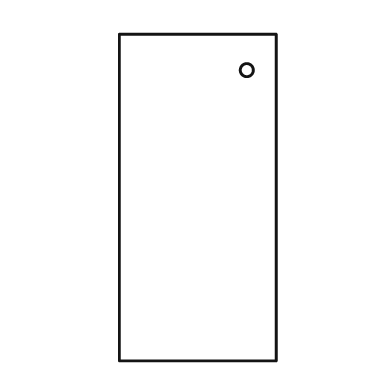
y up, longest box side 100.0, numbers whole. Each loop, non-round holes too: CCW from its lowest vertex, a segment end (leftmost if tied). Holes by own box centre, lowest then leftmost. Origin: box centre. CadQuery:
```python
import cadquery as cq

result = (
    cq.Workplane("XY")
    .moveTo(-24.0, -50.0)
    .lineTo(24.0, -50.0)
    .lineTo(24.0, 50.0)
    .lineTo(-24.0, 50.0)
    .close()
    .moveTo(15.0, 39.0)
    .circle(2.0)
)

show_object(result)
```